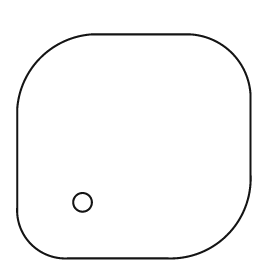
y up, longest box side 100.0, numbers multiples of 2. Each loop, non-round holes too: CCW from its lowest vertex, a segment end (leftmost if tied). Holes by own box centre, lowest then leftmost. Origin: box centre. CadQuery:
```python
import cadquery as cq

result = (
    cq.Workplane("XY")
    .moveTo(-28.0, -48.0)
    .lineTo(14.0, -48.0)
    .threePointArc((40.0, -38.0), (50.0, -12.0))
    .lineTo(50.0, 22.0)
    .threePointArc((42.0, 40.0), (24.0, 48.0))
    .lineTo(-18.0, 48.0)
    .threePointArc((-40.0, 38.0), (-50.0, 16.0))
    .lineTo(-50.0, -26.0)
    .threePointArc((-44.0, -42.0), (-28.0, -48.0))
    .close()
    .moveTo(-22.0, -24.0)
    .circle(4.0)
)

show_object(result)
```